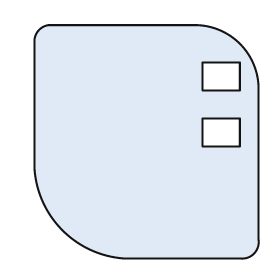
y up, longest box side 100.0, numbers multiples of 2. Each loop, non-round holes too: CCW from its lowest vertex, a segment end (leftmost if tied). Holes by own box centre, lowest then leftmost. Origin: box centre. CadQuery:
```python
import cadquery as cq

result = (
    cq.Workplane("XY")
    .moveTo(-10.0, -50.0)
    .lineTo(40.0, -50.0)
    .threePointArc((46.0, -48.0), (48.0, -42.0))
    .lineTo(48.0, 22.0)
    .threePointArc((40.0, 42.0), (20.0, 50.0))
    .lineTo(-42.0, 50.0)
    .threePointArc((-46.0, 48.0), (-48.0, 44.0))
    .lineTo(-48.0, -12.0)
    .threePointArc((-36.0, -38.0), (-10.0, -50.0))
    .close()
    .moveTo(24.0, -2.0)
    .lineTo(40.0, -2.0)
    .lineTo(40.0, 10.0)
    .lineTo(24.0, 10.0)
    .close()
    .moveTo(24.0, 22.0)
    .lineTo(40.0, 22.0)
    .lineTo(40.0, 34.0)
    .lineTo(24.0, 34.0)
    .close()
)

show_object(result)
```